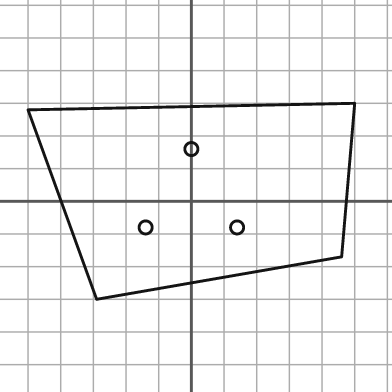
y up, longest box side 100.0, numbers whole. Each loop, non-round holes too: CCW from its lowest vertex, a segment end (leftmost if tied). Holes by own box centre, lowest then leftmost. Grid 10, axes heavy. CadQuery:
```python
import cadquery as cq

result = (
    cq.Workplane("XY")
    .moveTo(-29.0, -30.0)
    .lineTo(46.0, -17.0)
    .lineTo(50.0, 30.0)
    .lineTo(-50.0, 28.0)
    .close()
    .moveTo(-14.0, -8.0)
    .circle(2.0)
    .moveTo(14.0, -8.0)
    .circle(2.0)
    .moveTo(0.0, 16.0)
    .circle(2.0)
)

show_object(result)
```